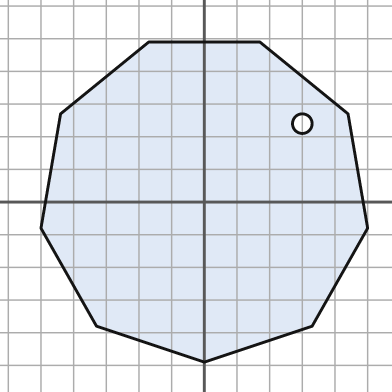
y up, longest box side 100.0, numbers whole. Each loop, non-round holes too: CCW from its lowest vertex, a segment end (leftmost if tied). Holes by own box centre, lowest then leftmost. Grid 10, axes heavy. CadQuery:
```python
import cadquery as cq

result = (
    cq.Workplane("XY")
    .moveTo(0.0, -49.0)
    .lineTo(33.0, -38.0)
    .lineTo(50.0, -8.0)
    .lineTo(44.0, 27.0)
    .lineTo(17.0, 49.0)
    .lineTo(-17.0, 49.0)
    .lineTo(-44.0, 27.0)
    .lineTo(-50.0, -8.0)
    .lineTo(-33.0, -38.0)
    .close()
    .moveTo(30.0, 24.0)
    .circle(3.0)
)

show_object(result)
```